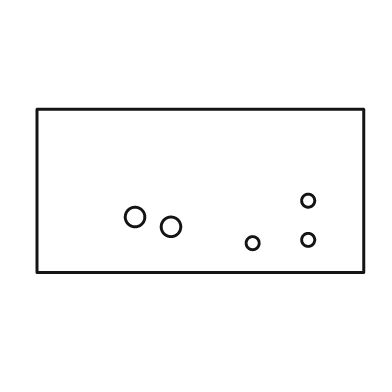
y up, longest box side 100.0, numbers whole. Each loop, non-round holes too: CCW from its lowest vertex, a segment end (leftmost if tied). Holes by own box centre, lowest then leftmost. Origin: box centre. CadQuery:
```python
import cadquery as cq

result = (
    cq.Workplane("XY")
    .moveTo(-50.0, -25.0)
    .lineTo(50.0, -25.0)
    .lineTo(50.0, 25.0)
    .lineTo(-50.0, 25.0)
    .close()
    .moveTo(16.0, -16.0)
    .circle(2.0)
    .moveTo(33.0, -15.0)
    .circle(2.0)
    .moveTo(-9.0, -11.0)
    .circle(3.0)
    .moveTo(-20.0, -8.0)
    .circle(3.0)
    .moveTo(33.0, -3.0)
    .circle(2.0)
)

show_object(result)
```